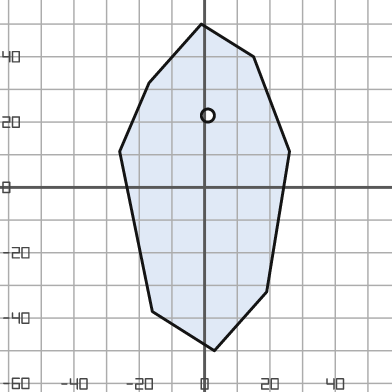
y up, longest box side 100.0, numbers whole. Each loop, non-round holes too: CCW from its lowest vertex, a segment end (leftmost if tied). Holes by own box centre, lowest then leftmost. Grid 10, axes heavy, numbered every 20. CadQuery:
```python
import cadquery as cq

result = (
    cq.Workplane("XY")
    .moveTo(3.0, -50.0)
    .lineTo(19.0, -32.0)
    .lineTo(26.0, 11.0)
    .lineTo(15.0, 40.0)
    .lineTo(-1.0, 50.0)
    .lineTo(-17.0, 32.0)
    .lineTo(-26.0, 11.0)
    .lineTo(-16.0, -38.0)
    .close()
    .moveTo(1.0, 22.0)
    .circle(2.0)
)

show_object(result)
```